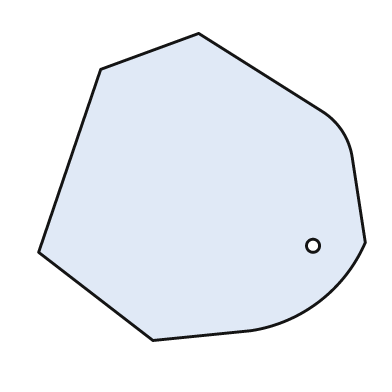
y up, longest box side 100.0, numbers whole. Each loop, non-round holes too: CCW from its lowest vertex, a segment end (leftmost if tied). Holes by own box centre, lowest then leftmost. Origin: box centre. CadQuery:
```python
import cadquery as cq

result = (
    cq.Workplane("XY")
    .moveTo(-15.0, -47.0)
    .lineTo(15.0, -44.0)
    .threePointArc((36.0, -35.0), (50.0, -17.0))
    .lineTo(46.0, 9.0)
    .threePointArc((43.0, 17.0), (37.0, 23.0))
    .lineTo(-1.0, 47.0)
    .lineTo(-31.0, 36.0)
    .lineTo(-50.0, -20.0)
    .close()
    .moveTo(34.0, -18.0)
    .circle(2.0)
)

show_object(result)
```